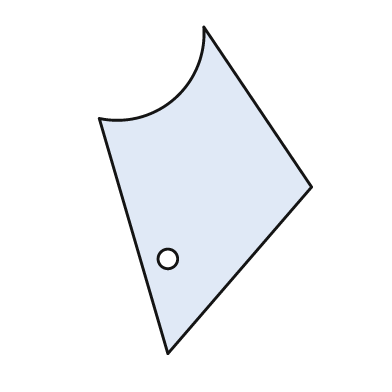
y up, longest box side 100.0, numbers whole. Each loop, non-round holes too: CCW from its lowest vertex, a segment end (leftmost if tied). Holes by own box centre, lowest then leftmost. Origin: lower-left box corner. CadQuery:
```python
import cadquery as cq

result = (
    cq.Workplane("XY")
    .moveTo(21.0, 0.0)
    .lineTo(65.0, 51.0)
    .lineTo(32.0, 100.0)
    .threePointArc((23.0, 78.0), (0.0, 72.0))
    .close()
    .moveTo(21.0, 29.0)
    .circle(3.0)
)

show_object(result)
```